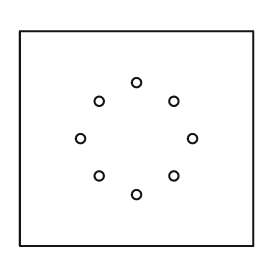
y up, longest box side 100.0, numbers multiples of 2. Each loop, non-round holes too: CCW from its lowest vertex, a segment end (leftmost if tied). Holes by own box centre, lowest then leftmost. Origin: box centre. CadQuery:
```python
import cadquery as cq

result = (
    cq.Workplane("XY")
    .moveTo(-50.0, -46.0)
    .lineTo(50.0, -46.0)
    .lineTo(50.0, 46.0)
    .lineTo(-50.0, 46.0)
    .close()
    .moveTo(0.0, -24.0)
    .circle(2.0)
    .moveTo(-16.0, -16.0)
    .circle(2.0)
    .moveTo(16.0, -16.0)
    .circle(2.0)
    .moveTo(-24.0, 0.0)
    .circle(2.0)
    .moveTo(24.0, 0.0)
    .circle(2.0)
    .moveTo(-16.0, 16.0)
    .circle(2.0)
    .moveTo(16.0, 16.0)
    .circle(2.0)
    .moveTo(0.0, 24.0)
    .circle(2.0)
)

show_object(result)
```